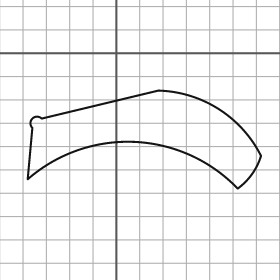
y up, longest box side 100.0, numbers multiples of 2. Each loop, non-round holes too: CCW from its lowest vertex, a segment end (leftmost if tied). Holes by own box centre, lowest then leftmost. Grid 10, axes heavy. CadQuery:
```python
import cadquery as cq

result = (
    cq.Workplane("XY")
    .moveTo(52.0, -58.0)
    .threePointArc((58.0, -52.0), (62.0, -44.0))
    .threePointArc((44.0, -24.0), (18.0, -16.0))
    .lineTo(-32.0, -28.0)
    .threePointArc((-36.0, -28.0), (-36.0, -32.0))
    .lineTo(-38.0, -54.0)
    .threePointArc((8.0, -38.0), (52.0, -58.0))
    .close()
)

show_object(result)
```